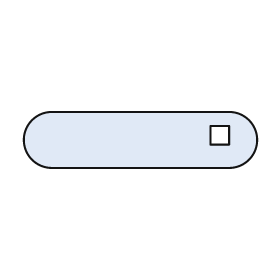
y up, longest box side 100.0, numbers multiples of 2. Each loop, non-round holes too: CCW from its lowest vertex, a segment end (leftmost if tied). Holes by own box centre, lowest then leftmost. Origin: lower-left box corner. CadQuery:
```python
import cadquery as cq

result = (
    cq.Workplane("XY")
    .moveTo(12.0, 0.0)
    .lineTo(88.0, 0.0)
    .threePointArc((100.0, 12.0), (88.0, 24.0))
    .lineTo(12.0, 24.0)
    .threePointArc((0.0, 12.0), (12.0, 0.0))
    .close()
    .moveTo(80.0, 10.0)
    .lineTo(88.0, 10.0)
    .lineTo(88.0, 18.0)
    .lineTo(80.0, 18.0)
    .close()
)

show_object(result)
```